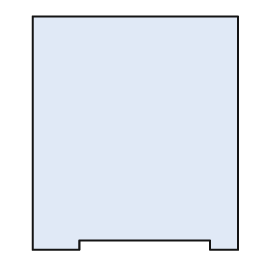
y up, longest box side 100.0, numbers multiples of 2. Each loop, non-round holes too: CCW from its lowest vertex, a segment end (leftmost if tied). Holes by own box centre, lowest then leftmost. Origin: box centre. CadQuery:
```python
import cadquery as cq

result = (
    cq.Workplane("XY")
    .moveTo(-44.0, -50.0)
    .lineTo(-24.0, -50.0)
    .lineTo(-24.0, -46.0)
    .lineTo(32.0, -46.0)
    .lineTo(32.0, -50.0)
    .lineTo(44.0, -50.0)
    .lineTo(44.0, 50.0)
    .lineTo(-44.0, 50.0)
    .close()
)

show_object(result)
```